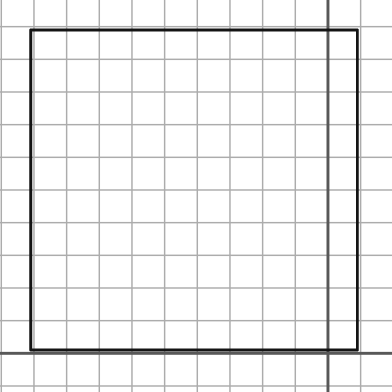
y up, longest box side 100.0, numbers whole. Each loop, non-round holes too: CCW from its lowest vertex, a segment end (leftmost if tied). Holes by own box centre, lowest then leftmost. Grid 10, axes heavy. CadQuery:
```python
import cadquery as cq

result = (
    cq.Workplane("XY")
    .moveTo(-91.0, 1.0)
    .lineTo(9.0, 1.0)
    .lineTo(9.0, 99.0)
    .lineTo(-91.0, 99.0)
    .close()
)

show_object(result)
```